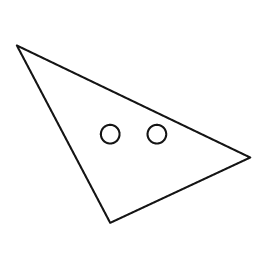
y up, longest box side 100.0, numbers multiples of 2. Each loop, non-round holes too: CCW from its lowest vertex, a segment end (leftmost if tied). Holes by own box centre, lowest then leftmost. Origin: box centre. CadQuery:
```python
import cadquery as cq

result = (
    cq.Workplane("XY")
    .moveTo(-10.0, -38.0)
    .lineTo(50.0, -10.0)
    .lineTo(-50.0, 38.0)
    .close()
    .moveTo(-10.0, 0.0)
    .circle(4.0)
    .moveTo(10.0, 0.0)
    .circle(4.0)
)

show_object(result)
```